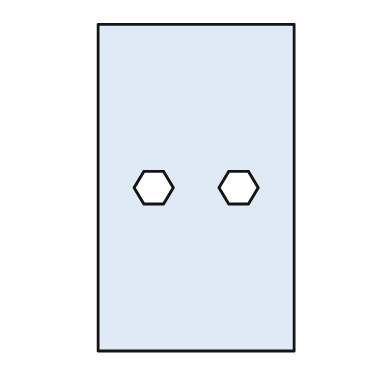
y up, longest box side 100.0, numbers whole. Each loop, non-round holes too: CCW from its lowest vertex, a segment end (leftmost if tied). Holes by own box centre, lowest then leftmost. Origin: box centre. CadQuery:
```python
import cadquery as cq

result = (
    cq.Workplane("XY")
    .moveTo(-30.0, -50.0)
    .lineTo(30.0, -50.0)
    .lineTo(30.0, 50.0)
    .lineTo(-30.0, 50.0)
    .close()
    .moveTo(-16.0, -5.0)
    .lineTo(-10.0, -5.0)
    .lineTo(-7.0, 0.0)
    .lineTo(-10.0, 5.0)
    .lineTo(-16.0, 5.0)
    .lineTo(-19.0, 0.0)
    .close()
    .moveTo(10.0, -5.0)
    .lineTo(16.0, -5.0)
    .lineTo(19.0, 0.0)
    .lineTo(16.0, 5.0)
    .lineTo(10.0, 5.0)
    .lineTo(7.0, 0.0)
    .close()
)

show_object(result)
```